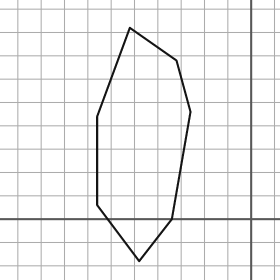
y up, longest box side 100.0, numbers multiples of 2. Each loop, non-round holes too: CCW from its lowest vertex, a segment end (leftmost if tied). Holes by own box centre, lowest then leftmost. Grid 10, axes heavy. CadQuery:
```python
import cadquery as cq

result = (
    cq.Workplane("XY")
    .moveTo(-48.0, -18.0)
    .lineTo(-34.0, 0.0)
    .lineTo(-26.0, 46.0)
    .lineTo(-32.0, 68.0)
    .lineTo(-52.0, 82.0)
    .lineTo(-66.0, 44.0)
    .lineTo(-66.0, 6.0)
    .close()
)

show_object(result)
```